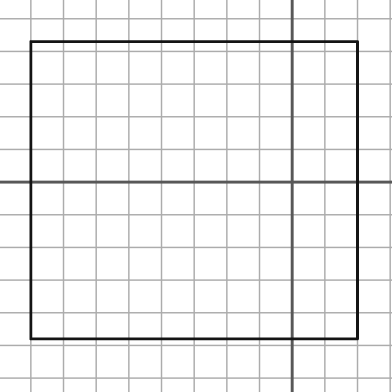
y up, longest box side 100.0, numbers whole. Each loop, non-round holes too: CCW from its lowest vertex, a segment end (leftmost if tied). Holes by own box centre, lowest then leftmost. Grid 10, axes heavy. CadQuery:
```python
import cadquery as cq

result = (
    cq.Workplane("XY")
    .moveTo(-80.0, -48.0)
    .lineTo(20.0, -48.0)
    .lineTo(20.0, 43.0)
    .lineTo(-80.0, 43.0)
    .close()
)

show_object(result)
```